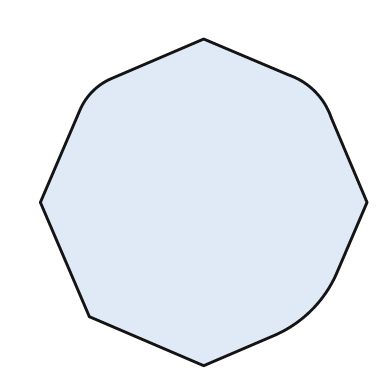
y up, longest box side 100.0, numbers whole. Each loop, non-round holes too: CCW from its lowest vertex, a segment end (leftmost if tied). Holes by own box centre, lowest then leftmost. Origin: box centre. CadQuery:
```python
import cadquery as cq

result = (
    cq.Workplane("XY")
    .moveTo(0.0, -50.0)
    .lineTo(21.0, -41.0)
    .threePointArc((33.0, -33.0), (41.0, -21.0))
    .lineTo(50.0, 0.0)
    .lineTo(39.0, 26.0)
    .threePointArc((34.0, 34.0), (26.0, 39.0))
    .lineTo(0.0, 50.0)
    .lineTo(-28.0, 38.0)
    .threePointArc((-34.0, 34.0), (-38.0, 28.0))
    .lineTo(-50.0, 0.0)
    .lineTo(-35.0, -35.0)
    .close()
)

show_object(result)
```